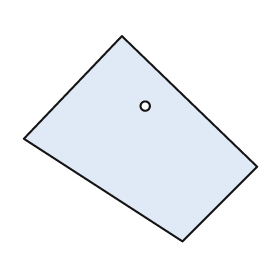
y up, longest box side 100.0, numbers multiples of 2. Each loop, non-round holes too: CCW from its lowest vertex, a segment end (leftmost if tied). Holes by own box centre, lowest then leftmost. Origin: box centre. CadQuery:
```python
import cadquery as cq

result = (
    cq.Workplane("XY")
    .moveTo(18.0, -44.0)
    .lineTo(50.0, -12.0)
    .lineTo(-8.0, 44.0)
    .lineTo(-50.0, 0.0)
    .close()
    .moveTo(2.0, 14.0)
    .circle(2.0)
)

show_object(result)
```